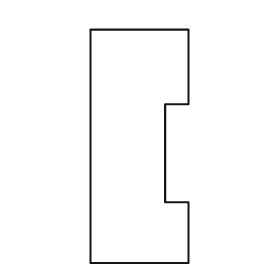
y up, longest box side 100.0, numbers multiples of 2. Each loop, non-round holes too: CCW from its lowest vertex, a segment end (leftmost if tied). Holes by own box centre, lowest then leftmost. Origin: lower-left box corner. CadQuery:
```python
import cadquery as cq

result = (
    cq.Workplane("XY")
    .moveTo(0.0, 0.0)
    .lineTo(42.0, 0.0)
    .lineTo(42.0, 26.0)
    .lineTo(32.0, 26.0)
    .lineTo(32.0, 68.0)
    .lineTo(42.0, 68.0)
    .lineTo(42.0, 100.0)
    .lineTo(0.0, 100.0)
    .close()
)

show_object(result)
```